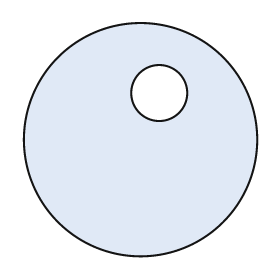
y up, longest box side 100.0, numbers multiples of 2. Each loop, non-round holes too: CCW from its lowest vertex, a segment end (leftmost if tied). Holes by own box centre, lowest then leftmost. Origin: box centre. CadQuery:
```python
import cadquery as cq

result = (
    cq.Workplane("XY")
    .moveTo(0.0, 0.0)
    .circle(50.0)
    .moveTo(8.0, 20.0)
    .circle(12.0)
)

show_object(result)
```